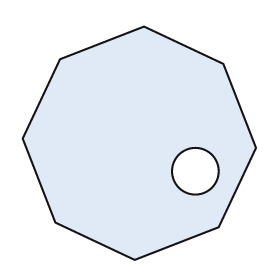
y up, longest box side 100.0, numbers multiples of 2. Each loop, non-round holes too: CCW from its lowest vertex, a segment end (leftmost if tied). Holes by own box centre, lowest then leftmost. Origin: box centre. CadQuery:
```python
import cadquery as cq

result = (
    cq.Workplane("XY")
    .moveTo(-2.0, -50.0)
    .lineTo(34.0, -36.0)
    .lineTo(50.0, -2.0)
    .lineTo(36.0, 34.0)
    .lineTo(2.0, 50.0)
    .lineTo(-34.0, 36.0)
    .lineTo(-50.0, 2.0)
    .lineTo(-36.0, -34.0)
    .close()
    .moveTo(24.0, -12.0)
    .circle(10.0)
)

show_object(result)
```